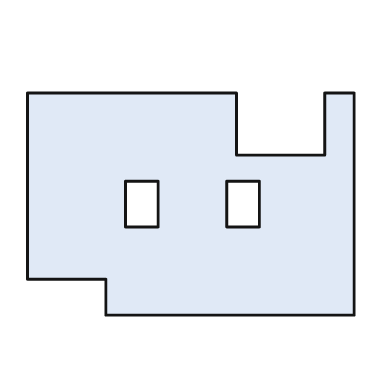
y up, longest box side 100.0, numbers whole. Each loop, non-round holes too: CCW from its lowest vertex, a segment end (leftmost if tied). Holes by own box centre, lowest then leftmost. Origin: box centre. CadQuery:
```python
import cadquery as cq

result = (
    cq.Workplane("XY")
    .moveTo(-26.0, -34.0)
    .lineTo(50.0, -34.0)
    .lineTo(50.0, 34.0)
    .lineTo(41.0, 34.0)
    .lineTo(41.0, 15.0)
    .lineTo(14.0, 15.0)
    .lineTo(14.0, 34.0)
    .lineTo(-50.0, 34.0)
    .lineTo(-50.0, -23.0)
    .lineTo(-26.0, -23.0)
    .close()
    .moveTo(-20.0, -7.0)
    .lineTo(-10.0, -7.0)
    .lineTo(-10.0, 7.0)
    .lineTo(-20.0, 7.0)
    .close()
    .moveTo(11.0, -7.0)
    .lineTo(21.0, -7.0)
    .lineTo(21.0, 7.0)
    .lineTo(11.0, 7.0)
    .close()
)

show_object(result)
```